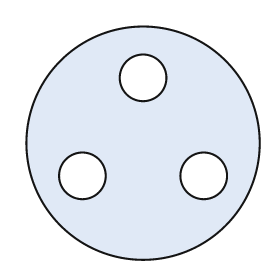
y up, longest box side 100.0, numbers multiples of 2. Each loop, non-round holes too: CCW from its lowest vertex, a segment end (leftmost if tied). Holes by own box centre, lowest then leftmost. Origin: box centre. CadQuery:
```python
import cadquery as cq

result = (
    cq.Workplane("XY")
    .moveTo(0.0, 0.0)
    .circle(50.0)
    .moveTo(-26.0, -14.0)
    .circle(10.0)
    .moveTo(26.0, -14.0)
    .circle(10.0)
    .moveTo(0.0, 28.0)
    .circle(10.0)
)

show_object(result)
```